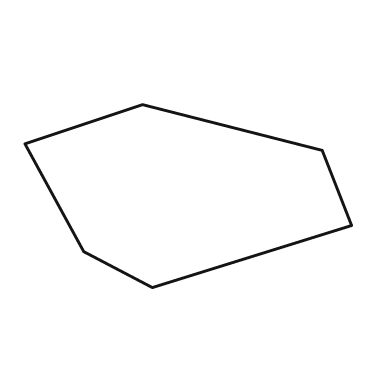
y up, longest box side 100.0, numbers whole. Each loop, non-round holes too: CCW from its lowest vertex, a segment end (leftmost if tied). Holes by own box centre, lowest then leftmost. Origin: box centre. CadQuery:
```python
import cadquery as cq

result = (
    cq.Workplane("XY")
    .moveTo(-11.0, -28.0)
    .lineTo(50.0, -9.0)
    .lineTo(41.0, 14.0)
    .lineTo(-14.0, 28.0)
    .lineTo(-50.0, 16.0)
    .lineTo(-32.0, -17.0)
    .close()
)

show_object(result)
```